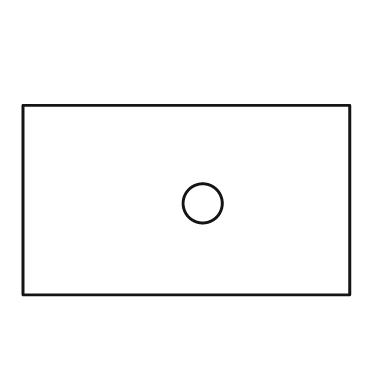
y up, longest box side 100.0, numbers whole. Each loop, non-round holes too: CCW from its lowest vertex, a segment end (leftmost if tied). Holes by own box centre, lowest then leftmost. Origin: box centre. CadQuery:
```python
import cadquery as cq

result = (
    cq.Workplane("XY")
    .moveTo(-50.0, -29.0)
    .lineTo(50.0, -29.0)
    .lineTo(50.0, 29.0)
    .lineTo(-50.0, 29.0)
    .close()
    .moveTo(5.0, -1.0)
    .circle(6.0)
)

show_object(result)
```